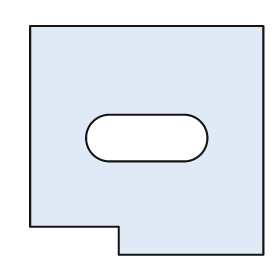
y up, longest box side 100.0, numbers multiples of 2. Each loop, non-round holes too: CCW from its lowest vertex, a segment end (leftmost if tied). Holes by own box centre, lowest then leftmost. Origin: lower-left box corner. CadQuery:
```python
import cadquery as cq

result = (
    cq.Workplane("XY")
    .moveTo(38.0, 0.0)
    .lineTo(100.0, 0.0)
    .lineTo(100.0, 98.0)
    .lineTo(0.0, 98.0)
    .lineTo(0.0, 12.0)
    .lineTo(38.0, 12.0)
    .close()
    .moveTo(34.0, 40.0)
    .lineTo(66.0, 40.0)
    .threePointArc((76.0, 50.0), (66.0, 60.0))
    .lineTo(34.0, 60.0)
    .threePointArc((24.0, 50.0), (34.0, 40.0))
    .close()
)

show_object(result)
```